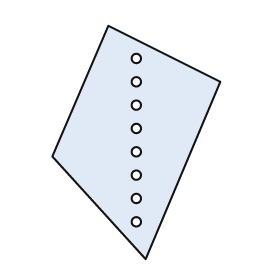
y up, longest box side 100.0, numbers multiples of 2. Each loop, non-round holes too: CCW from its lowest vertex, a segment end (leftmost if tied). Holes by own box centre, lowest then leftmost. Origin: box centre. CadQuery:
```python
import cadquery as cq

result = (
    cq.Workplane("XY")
    .moveTo(4.0, -50.0)
    .lineTo(36.0, 26.0)
    .lineTo(-12.0, 50.0)
    .lineTo(-36.0, -6.0)
    .close()
    .moveTo(0.0, -34.0)
    .circle(2.0)
    .moveTo(0.0, -24.0)
    .circle(2.0)
    .moveTo(0.0, -14.0)
    .circle(2.0)
    .moveTo(0.0, -4.0)
    .circle(2.0)
    .moveTo(0.0, 6.0)
    .circle(2.0)
    .moveTo(0.0, 16.0)
    .circle(2.0)
    .moveTo(0.0, 26.0)
    .circle(2.0)
    .moveTo(0.0, 36.0)
    .circle(2.0)
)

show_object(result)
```